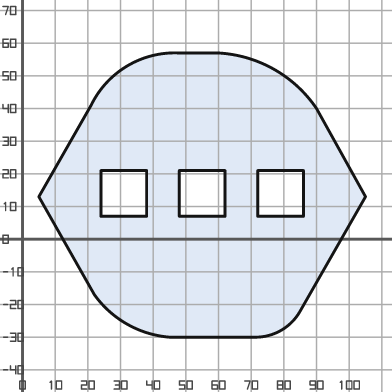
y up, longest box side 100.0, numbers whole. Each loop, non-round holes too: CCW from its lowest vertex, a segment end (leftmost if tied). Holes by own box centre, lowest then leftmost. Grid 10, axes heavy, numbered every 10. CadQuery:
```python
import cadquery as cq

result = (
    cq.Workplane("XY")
    .moveTo(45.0, -30.0)
    .lineTo(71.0, -30.0)
    .threePointArc((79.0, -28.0), (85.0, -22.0))
    .lineTo(105.0, 13.0)
    .lineTo(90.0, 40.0)
    .threePointArc((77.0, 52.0), (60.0, 57.0))
    .lineTo(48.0, 57.0)
    .threePointArc((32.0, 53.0), (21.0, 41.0))
    .lineTo(5.0, 13.0)
    .lineTo(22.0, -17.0)
    .threePointArc((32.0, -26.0), (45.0, -30.0))
    .close()
    .moveTo(24.0, 7.0)
    .lineTo(38.0, 7.0)
    .lineTo(38.0, 21.0)
    .lineTo(24.0, 21.0)
    .close()
    .moveTo(48.0, 7.0)
    .lineTo(62.0, 7.0)
    .lineTo(62.0, 21.0)
    .lineTo(48.0, 21.0)
    .close()
    .moveTo(72.0, 7.0)
    .lineTo(86.0, 7.0)
    .lineTo(86.0, 21.0)
    .lineTo(72.0, 21.0)
    .close()
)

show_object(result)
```